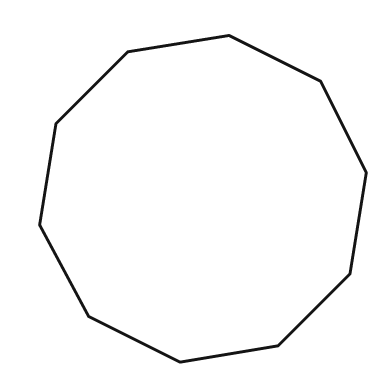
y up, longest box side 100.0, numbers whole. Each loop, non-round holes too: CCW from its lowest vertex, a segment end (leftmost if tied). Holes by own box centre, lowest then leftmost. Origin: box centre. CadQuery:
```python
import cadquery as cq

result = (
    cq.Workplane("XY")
    .moveTo(-7.0, -50.0)
    .lineTo(23.0, -45.0)
    .lineTo(45.0, -23.0)
    .lineTo(50.0, 8.0)
    .lineTo(36.0, 36.0)
    .lineTo(8.0, 50.0)
    .lineTo(-23.0, 45.0)
    .lineTo(-45.0, 23.0)
    .lineTo(-50.0, -8.0)
    .lineTo(-35.0, -36.0)
    .close()
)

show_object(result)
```